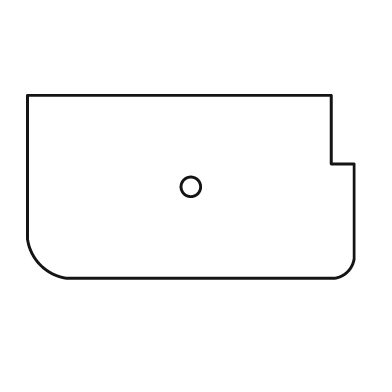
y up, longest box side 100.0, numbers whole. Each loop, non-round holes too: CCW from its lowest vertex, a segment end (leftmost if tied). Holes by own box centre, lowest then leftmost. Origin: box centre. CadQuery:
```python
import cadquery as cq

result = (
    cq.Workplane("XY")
    .moveTo(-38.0, -28.0)
    .lineTo(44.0, -28.0)
    .threePointArc((48.0, -26.0), (50.0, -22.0))
    .lineTo(50.0, 7.0)
    .lineTo(43.0, 7.0)
    .lineTo(43.0, 28.0)
    .lineTo(-50.0, 28.0)
    .lineTo(-50.0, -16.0)
    .threePointArc((-46.0, -24.0), (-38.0, -28.0))
    .close()
    .moveTo(0.0, 0.0)
    .circle(3.0)
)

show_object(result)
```